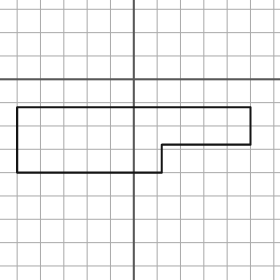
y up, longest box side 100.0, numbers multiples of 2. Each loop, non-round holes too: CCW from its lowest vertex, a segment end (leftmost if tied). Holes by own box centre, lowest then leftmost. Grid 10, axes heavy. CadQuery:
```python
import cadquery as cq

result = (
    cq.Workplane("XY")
    .moveTo(-50.0, -40.0)
    .lineTo(12.0, -40.0)
    .lineTo(12.0, -28.0)
    .lineTo(50.0, -28.0)
    .lineTo(50.0, -12.0)
    .lineTo(-50.0, -12.0)
    .close()
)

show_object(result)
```